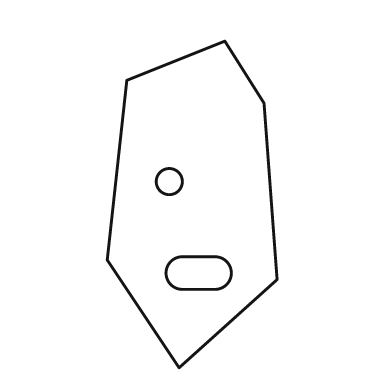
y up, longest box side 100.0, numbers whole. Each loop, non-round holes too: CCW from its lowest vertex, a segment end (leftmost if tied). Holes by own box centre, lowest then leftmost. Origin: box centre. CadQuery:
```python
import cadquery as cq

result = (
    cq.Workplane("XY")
    .moveTo(-4.0, -50.0)
    .lineTo(26.0, -23.0)
    .lineTo(22.0, 31.0)
    .lineTo(10.0, 50.0)
    .lineTo(-20.0, 38.0)
    .lineTo(-26.0, -17.0)
    .close()
    .moveTo(-3.0, -26.0)
    .lineTo(7.0, -26.0)
    .threePointArc((12.0, -21.0), (7.0, -16.0))
    .lineTo(-3.0, -16.0)
    .threePointArc((-8.0, -21.0), (-3.0, -26.0))
    .close()
    .moveTo(-7.0, 7.0)
    .circle(4.0)
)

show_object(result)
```